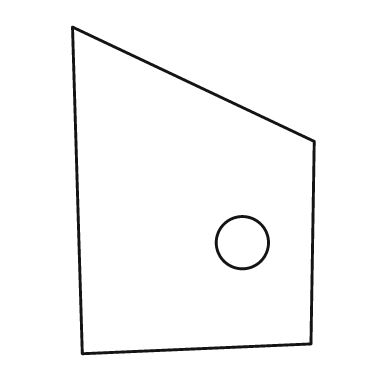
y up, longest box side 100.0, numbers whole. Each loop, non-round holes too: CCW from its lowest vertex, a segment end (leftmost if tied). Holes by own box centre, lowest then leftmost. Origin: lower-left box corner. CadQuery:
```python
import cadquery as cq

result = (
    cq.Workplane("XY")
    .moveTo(3.0, 0.0)
    .lineTo(73.0, 3.0)
    .lineTo(74.0, 65.0)
    .lineTo(0.0, 100.0)
    .close()
    .moveTo(52.0, 34.0)
    .circle(8.0)
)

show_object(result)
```